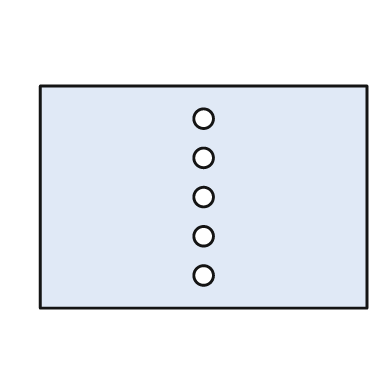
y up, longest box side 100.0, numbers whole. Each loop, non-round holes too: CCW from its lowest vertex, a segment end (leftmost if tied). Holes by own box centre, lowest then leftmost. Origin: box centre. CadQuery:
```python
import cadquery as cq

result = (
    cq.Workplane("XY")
    .moveTo(-50.0, -34.0)
    .lineTo(50.0, -34.0)
    .lineTo(50.0, 34.0)
    .lineTo(-50.0, 34.0)
    .close()
    .moveTo(0.0, -24.0)
    .circle(3.0)
    .moveTo(0.0, -12.0)
    .circle(3.0)
    .moveTo(0.0, 0.0)
    .circle(3.0)
    .moveTo(0.0, 12.0)
    .circle(3.0)
    .moveTo(0.0, 24.0)
    .circle(3.0)
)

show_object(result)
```